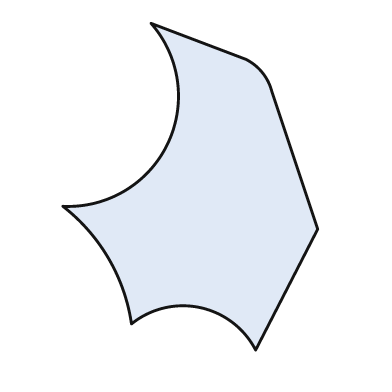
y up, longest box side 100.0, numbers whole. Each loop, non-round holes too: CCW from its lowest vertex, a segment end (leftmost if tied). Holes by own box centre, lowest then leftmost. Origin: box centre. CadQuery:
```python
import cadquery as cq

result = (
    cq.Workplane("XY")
    .moveTo(20.0, -50.0)
    .lineTo(39.0, -13.0)
    .lineTo(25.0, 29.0)
    .threePointArc((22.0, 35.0), (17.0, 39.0))
    .lineTo(-12.0, 50.0)
    .threePointArc((-7.0, 13.0), (-39.0, -6.0))
    .threePointArc((-25.0, -22.0), (-18.0, -42.0))
    .threePointArc((3.0, -37.0), (20.0, -50.0))
    .close()
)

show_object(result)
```